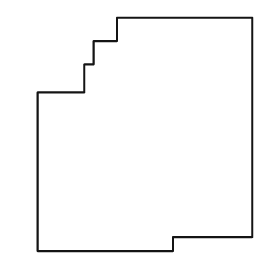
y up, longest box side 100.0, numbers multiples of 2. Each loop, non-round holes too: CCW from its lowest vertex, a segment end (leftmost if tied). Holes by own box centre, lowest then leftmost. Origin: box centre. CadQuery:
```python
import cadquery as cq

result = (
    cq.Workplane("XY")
    .moveTo(-46.0, -50.0)
    .lineTo(12.0, -50.0)
    .lineTo(12.0, -44.0)
    .lineTo(46.0, -44.0)
    .lineTo(46.0, 50.0)
    .lineTo(-12.0, 50.0)
    .lineTo(-12.0, 40.0)
    .lineTo(-22.0, 40.0)
    .lineTo(-22.0, 30.0)
    .lineTo(-26.0, 30.0)
    .lineTo(-26.0, 18.0)
    .lineTo(-46.0, 18.0)
    .close()
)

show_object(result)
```